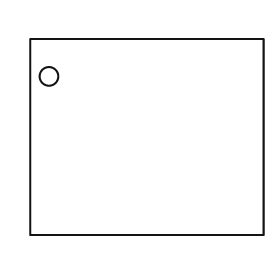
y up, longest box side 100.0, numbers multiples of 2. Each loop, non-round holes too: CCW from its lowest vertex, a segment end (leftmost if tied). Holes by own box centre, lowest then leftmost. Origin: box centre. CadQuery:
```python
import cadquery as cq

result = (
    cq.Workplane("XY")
    .moveTo(-50.0, -42.0)
    .lineTo(50.0, -42.0)
    .lineTo(50.0, 42.0)
    .lineTo(-50.0, 42.0)
    .close()
    .moveTo(-42.0, 26.0)
    .circle(4.0)
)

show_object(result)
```